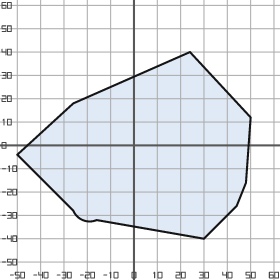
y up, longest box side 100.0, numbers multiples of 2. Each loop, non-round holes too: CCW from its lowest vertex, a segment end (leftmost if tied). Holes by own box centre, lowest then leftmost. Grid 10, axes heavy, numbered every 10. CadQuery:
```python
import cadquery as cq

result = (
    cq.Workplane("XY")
    .moveTo(30.0, -40.0)
    .lineTo(44.0, -26.0)
    .lineTo(48.0, -16.0)
    .lineTo(50.0, 12.0)
    .lineTo(24.0, 40.0)
    .lineTo(-26.0, 18.0)
    .lineTo(-50.0, -4.0)
    .lineTo(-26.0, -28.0)
    .threePointArc((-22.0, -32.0), (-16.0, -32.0))
    .close()
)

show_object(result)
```